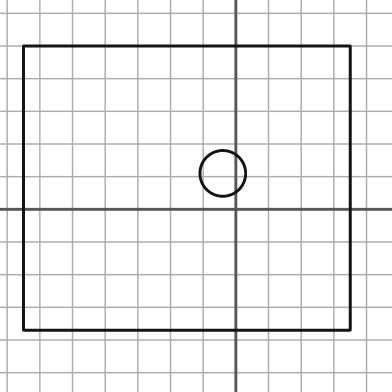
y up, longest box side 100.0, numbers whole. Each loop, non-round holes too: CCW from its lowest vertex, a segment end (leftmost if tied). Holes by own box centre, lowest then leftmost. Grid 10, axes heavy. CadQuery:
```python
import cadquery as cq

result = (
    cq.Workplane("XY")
    .moveTo(-65.0, -37.0)
    .lineTo(35.0, -37.0)
    .lineTo(35.0, 50.0)
    .lineTo(-65.0, 50.0)
    .close()
    .moveTo(-4.0, 11.0)
    .circle(7.0)
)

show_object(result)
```